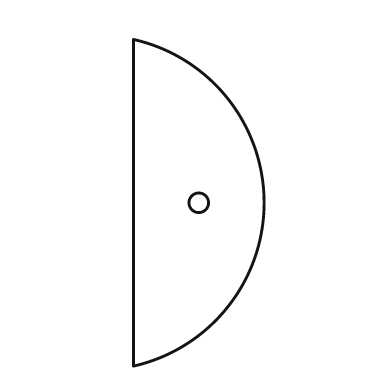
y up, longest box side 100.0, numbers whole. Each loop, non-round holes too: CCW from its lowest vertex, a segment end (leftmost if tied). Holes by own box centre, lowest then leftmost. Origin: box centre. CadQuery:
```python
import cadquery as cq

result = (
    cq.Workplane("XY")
    .moveTo(-20.0, -50.0)
    .threePointArc((20.0, 0.0), (-20.0, 50.0))
    .close()
    .moveTo(0.0, 0.0)
    .circle(3.0)
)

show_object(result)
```